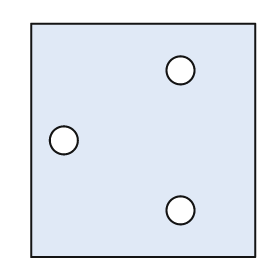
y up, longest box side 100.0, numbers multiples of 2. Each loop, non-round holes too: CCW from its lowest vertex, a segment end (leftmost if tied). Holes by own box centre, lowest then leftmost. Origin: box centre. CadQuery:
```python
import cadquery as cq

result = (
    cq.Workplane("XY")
    .moveTo(-48.0, -50.0)
    .lineTo(48.0, -50.0)
    .lineTo(48.0, 50.0)
    .lineTo(-48.0, 50.0)
    .close()
    .moveTo(16.0, -30.0)
    .circle(6.0)
    .moveTo(-34.0, 0.0)
    .circle(6.0)
    .moveTo(16.0, 30.0)
    .circle(6.0)
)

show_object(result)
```